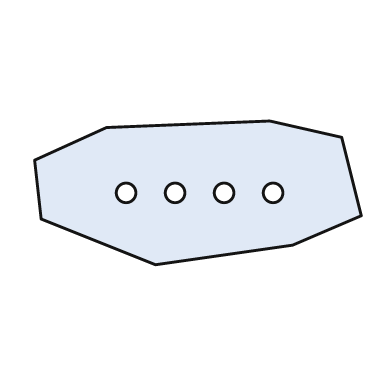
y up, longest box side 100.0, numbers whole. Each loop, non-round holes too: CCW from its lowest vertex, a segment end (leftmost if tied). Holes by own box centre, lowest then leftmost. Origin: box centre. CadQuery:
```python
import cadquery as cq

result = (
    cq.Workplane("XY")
    .moveTo(-13.0, -22.0)
    .lineTo(29.0, -16.0)
    .lineTo(50.0, -7.0)
    .lineTo(44.0, 17.0)
    .lineTo(22.0, 22.0)
    .lineTo(-28.0, 20.0)
    .lineTo(-50.0, 10.0)
    .lineTo(-48.0, -8.0)
    .close()
    .moveTo(-22.0, 0.0)
    .circle(3.0)
    .moveTo(-7.0, 0.0)
    .circle(3.0)
    .moveTo(8.0, 0.0)
    .circle(3.0)
    .moveTo(23.0, 0.0)
    .circle(3.0)
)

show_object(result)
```